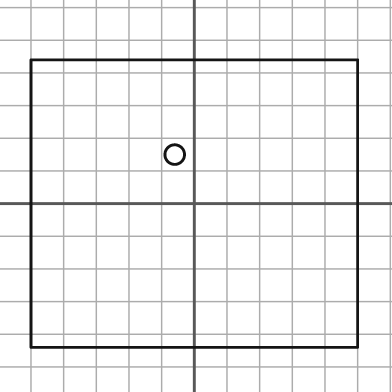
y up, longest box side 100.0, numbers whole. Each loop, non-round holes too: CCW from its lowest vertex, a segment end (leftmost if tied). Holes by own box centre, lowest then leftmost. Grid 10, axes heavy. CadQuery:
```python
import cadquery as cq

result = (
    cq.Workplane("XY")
    .moveTo(-50.0, -44.0)
    .lineTo(50.0, -44.0)
    .lineTo(50.0, 44.0)
    .lineTo(-50.0, 44.0)
    .close()
    .moveTo(-6.0, 15.0)
    .circle(3.0)
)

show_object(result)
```